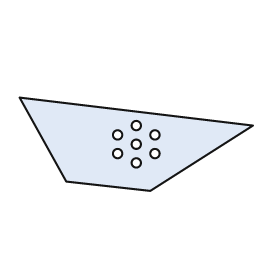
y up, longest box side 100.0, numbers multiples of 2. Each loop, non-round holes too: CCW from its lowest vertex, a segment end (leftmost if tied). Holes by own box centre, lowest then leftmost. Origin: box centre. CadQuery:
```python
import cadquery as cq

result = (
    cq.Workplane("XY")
    .moveTo(6.0, -20.0)
    .lineTo(50.0, 8.0)
    .lineTo(-50.0, 20.0)
    .lineTo(-30.0, -16.0)
    .close()
    .moveTo(0.0, -8.0)
    .circle(2.0)
    .moveTo(-8.0, -4.0)
    .circle(2.0)
    .moveTo(8.0, -4.0)
    .circle(2.0)
    .moveTo(0.0, 0.0)
    .circle(2.0)
    .moveTo(-8.0, 4.0)
    .circle(2.0)
    .moveTo(8.0, 4.0)
    .circle(2.0)
    .moveTo(0.0, 8.0)
    .circle(2.0)
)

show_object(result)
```